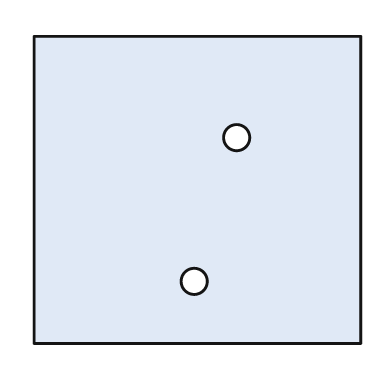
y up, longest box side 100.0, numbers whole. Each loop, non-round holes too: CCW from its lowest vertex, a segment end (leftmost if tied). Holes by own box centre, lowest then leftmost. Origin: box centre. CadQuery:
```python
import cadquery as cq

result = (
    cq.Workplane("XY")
    .moveTo(-50.0, -47.0)
    .lineTo(50.0, -47.0)
    .lineTo(50.0, 47.0)
    .lineTo(-50.0, 47.0)
    .close()
    .moveTo(-1.0, -28.0)
    .circle(4.0)
    .moveTo(12.0, 16.0)
    .circle(4.0)
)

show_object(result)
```